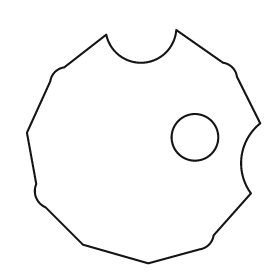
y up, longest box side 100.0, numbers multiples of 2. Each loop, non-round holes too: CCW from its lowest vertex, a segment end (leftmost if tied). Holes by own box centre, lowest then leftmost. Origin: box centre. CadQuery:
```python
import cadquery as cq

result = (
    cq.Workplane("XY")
    .moveTo(2.0, -50.0)
    .lineTo(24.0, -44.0)
    .threePointArc((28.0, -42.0), (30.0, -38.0))
    .lineTo(46.0, -20.0)
    .threePointArc((42.0, -4.0), (50.0, 10.0))
    .lineTo(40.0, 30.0)
    .threePointArc((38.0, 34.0), (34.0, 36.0))
    .lineTo(14.0, 50.0)
    .threePointArc((0.0, 36.0), (-16.0, 48.0))
    .lineTo(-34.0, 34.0)
    .threePointArc((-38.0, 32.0), (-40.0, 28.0))
    .lineTo(-50.0, 6.0)
    .lineTo(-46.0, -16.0)
    .threePointArc((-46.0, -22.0), (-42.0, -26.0))
    .lineTo(-26.0, -42.0)
    .close()
    .moveTo(22.0, 4.0)
    .circle(10.0)
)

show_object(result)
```